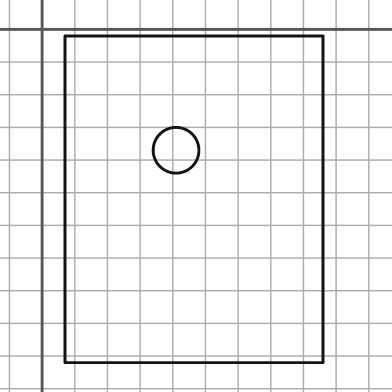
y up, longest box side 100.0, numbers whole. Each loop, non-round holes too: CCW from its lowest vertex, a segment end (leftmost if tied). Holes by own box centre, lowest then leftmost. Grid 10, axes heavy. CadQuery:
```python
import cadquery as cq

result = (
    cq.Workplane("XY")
    .moveTo(7.0, -102.0)
    .lineTo(86.0, -102.0)
    .lineTo(86.0, -2.0)
    .lineTo(7.0, -2.0)
    .close()
    .moveTo(41.0, -37.0)
    .circle(7.0)
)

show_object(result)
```